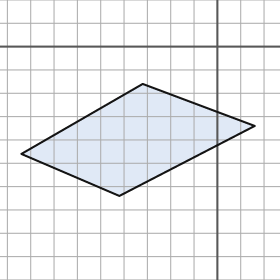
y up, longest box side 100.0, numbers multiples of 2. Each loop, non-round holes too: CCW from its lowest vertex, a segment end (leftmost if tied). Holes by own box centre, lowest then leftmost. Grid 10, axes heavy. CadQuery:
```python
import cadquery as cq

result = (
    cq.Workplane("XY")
    .moveTo(-42.0, -64.0)
    .lineTo(16.0, -34.0)
    .lineTo(-32.0, -16.0)
    .lineTo(-84.0, -46.0)
    .close()
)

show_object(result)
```